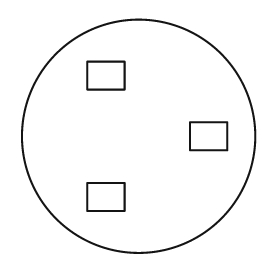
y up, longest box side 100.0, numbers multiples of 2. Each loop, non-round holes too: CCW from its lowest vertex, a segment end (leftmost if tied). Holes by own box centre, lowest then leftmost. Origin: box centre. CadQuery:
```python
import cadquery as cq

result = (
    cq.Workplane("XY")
    .moveTo(0.0, 0.0)
    .circle(50.0)
    .moveTo(-22.0, -32.0)
    .lineTo(-6.0, -32.0)
    .lineTo(-6.0, -20.0)
    .lineTo(-22.0, -20.0)
    .close()
    .moveTo(22.0, -6.0)
    .lineTo(38.0, -6.0)
    .lineTo(38.0, 6.0)
    .lineTo(22.0, 6.0)
    .close()
    .moveTo(-22.0, 20.0)
    .lineTo(-6.0, 20.0)
    .lineTo(-6.0, 32.0)
    .lineTo(-22.0, 32.0)
    .close()
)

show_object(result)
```